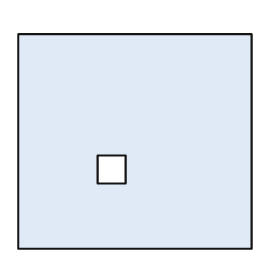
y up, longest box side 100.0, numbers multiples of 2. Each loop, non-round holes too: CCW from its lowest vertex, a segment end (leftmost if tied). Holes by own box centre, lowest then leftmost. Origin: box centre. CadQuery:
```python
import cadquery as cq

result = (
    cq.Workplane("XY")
    .moveTo(-50.0, -46.0)
    .lineTo(50.0, -46.0)
    .lineTo(50.0, 46.0)
    .lineTo(-50.0, 46.0)
    .close()
    .moveTo(-16.0, -18.0)
    .lineTo(-4.0, -18.0)
    .lineTo(-4.0, -6.0)
    .lineTo(-16.0, -6.0)
    .close()
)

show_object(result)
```